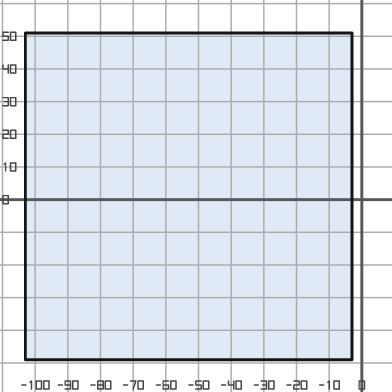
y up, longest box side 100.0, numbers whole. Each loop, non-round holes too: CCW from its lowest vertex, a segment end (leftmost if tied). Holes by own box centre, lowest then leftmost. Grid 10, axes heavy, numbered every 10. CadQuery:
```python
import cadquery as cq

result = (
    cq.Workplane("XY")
    .moveTo(-103.0, -49.0)
    .lineTo(-3.0, -49.0)
    .lineTo(-3.0, 51.0)
    .lineTo(-103.0, 51.0)
    .close()
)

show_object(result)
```